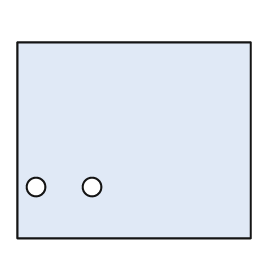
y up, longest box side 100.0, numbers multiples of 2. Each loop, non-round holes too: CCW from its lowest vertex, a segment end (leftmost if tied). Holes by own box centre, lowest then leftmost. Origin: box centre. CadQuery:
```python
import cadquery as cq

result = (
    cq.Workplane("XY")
    .moveTo(-50.0, -42.0)
    .lineTo(50.0, -42.0)
    .lineTo(50.0, 42.0)
    .lineTo(-50.0, 42.0)
    .close()
    .moveTo(-42.0, -20.0)
    .circle(4.0)
    .moveTo(-18.0, -20.0)
    .circle(4.0)
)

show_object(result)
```